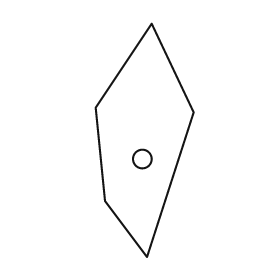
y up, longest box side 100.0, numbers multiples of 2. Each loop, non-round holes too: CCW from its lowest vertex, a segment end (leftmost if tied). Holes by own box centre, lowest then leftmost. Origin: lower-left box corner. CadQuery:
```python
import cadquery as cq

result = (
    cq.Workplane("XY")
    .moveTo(22.0, 0.0)
    .lineTo(42.0, 62.0)
    .lineTo(24.0, 100.0)
    .lineTo(0.0, 64.0)
    .lineTo(4.0, 24.0)
    .close()
    .moveTo(20.0, 42.0)
    .circle(4.0)
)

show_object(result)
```